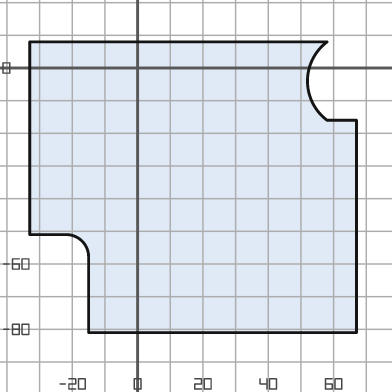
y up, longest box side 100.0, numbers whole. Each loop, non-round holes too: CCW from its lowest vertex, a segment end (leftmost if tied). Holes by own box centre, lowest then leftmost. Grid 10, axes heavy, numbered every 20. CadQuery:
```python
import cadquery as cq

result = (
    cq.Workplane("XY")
    .moveTo(-15.0, -81.0)
    .lineTo(67.0, -81.0)
    .lineTo(67.0, -16.0)
    .lineTo(58.0, -16.0)
    .threePointArc((52.0, -4.0), (58.0, 8.0))
    .lineTo(-33.0, 8.0)
    .lineTo(-33.0, -51.0)
    .lineTo(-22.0, -51.0)
    .threePointArc((-17.0, -53.0), (-15.0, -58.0))
    .close()
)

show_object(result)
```